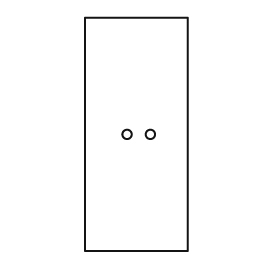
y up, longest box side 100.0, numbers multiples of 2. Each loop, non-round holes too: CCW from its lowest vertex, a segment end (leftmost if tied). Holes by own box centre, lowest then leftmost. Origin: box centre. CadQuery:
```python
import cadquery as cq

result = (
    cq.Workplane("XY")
    .moveTo(-22.0, -50.0)
    .lineTo(22.0, -50.0)
    .lineTo(22.0, 50.0)
    .lineTo(-22.0, 50.0)
    .close()
    .moveTo(-4.0, 0.0)
    .circle(2.0)
    .moveTo(6.0, 0.0)
    .circle(2.0)
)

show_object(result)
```